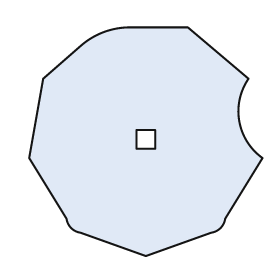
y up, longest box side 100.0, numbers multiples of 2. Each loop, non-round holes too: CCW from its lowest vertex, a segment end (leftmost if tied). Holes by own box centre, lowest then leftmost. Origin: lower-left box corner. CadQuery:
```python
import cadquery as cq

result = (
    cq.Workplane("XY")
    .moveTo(50.0, 0.0)
    .lineTo(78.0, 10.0)
    .threePointArc((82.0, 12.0), (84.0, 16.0))
    .lineTo(100.0, 42.0)
    .threePointArc((90.0, 58.0), (94.0, 76.0))
    .lineTo(68.0, 98.0)
    .lineTo(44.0, 98.0)
    .threePointArc((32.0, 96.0), (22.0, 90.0))
    .lineTo(6.0, 76.0)
    .lineTo(0.0, 42.0)
    .lineTo(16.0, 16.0)
    .threePointArc((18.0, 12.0), (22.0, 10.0))
    .close()
    .moveTo(46.0, 46.0)
    .lineTo(54.0, 46.0)
    .lineTo(54.0, 54.0)
    .lineTo(46.0, 54.0)
    .close()
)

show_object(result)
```